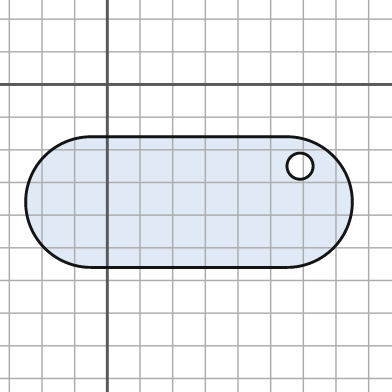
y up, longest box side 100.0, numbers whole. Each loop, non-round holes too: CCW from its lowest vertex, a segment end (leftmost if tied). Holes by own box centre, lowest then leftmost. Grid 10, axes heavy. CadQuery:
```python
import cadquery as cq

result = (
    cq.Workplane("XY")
    .moveTo(-5.0, -56.0)
    .lineTo(55.0, -56.0)
    .threePointArc((75.0, -36.0), (55.0, -16.0))
    .lineTo(-5.0, -16.0)
    .threePointArc((-25.0, -36.0), (-5.0, -56.0))
    .close()
    .moveTo(59.0, -25.0)
    .circle(4.0)
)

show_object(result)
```